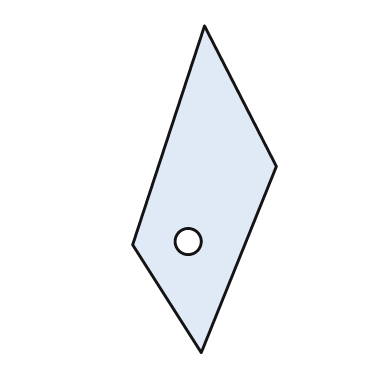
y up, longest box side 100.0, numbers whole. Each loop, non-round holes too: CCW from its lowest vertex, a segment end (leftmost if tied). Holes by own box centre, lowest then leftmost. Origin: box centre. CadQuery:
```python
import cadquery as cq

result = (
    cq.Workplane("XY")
    .moveTo(-1.0, -50.0)
    .lineTo(22.0, 7.0)
    .lineTo(0.0, 50.0)
    .lineTo(-22.0, -17.0)
    .close()
    .moveTo(-5.0, -16.0)
    .circle(4.0)
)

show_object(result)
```